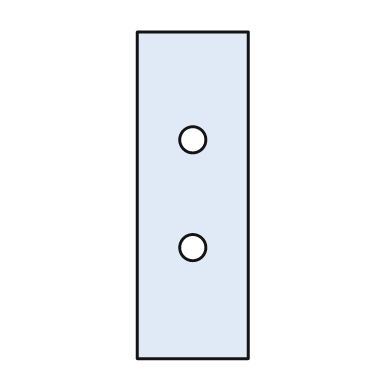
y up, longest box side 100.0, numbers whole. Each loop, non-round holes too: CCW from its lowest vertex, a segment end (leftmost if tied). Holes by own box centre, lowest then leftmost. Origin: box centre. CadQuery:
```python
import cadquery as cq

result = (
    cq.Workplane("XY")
    .moveTo(-17.0, -50.0)
    .lineTo(17.0, -50.0)
    .lineTo(17.0, 50.0)
    .lineTo(-17.0, 50.0)
    .close()
    .moveTo(0.0, -16.0)
    .circle(4.0)
    .moveTo(0.0, 17.0)
    .circle(4.0)
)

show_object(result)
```